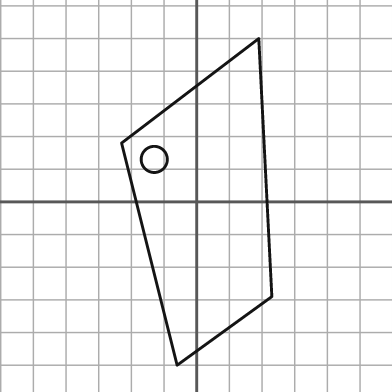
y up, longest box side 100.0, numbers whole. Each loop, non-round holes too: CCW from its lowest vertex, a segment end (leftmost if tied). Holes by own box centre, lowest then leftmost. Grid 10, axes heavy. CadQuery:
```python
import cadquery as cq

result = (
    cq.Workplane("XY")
    .moveTo(-6.0, -50.0)
    .lineTo(23.0, -29.0)
    .lineTo(19.0, 50.0)
    .lineTo(-23.0, 18.0)
    .close()
    .moveTo(-13.0, 13.0)
    .circle(4.0)
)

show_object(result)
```